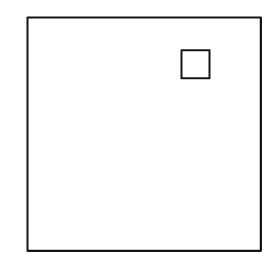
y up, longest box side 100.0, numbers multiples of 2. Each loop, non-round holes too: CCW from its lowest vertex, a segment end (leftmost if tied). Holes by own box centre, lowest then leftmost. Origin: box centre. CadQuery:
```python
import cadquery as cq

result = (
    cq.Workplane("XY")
    .moveTo(-50.0, -50.0)
    .lineTo(50.0, -50.0)
    .lineTo(50.0, 50.0)
    .lineTo(-50.0, 50.0)
    .close()
    .moveTo(16.0, 24.0)
    .lineTo(28.0, 24.0)
    .lineTo(28.0, 36.0)
    .lineTo(16.0, 36.0)
    .close()
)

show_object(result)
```